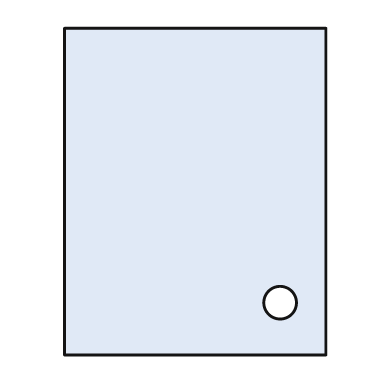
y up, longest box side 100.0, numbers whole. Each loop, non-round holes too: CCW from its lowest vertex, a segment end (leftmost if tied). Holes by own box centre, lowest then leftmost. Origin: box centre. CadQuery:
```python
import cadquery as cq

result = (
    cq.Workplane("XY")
    .moveTo(-40.0, -50.0)
    .lineTo(40.0, -50.0)
    .lineTo(40.0, 50.0)
    .lineTo(-40.0, 50.0)
    .close()
    .moveTo(26.0, -34.0)
    .circle(5.0)
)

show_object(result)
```